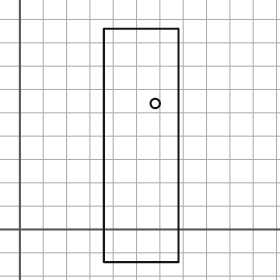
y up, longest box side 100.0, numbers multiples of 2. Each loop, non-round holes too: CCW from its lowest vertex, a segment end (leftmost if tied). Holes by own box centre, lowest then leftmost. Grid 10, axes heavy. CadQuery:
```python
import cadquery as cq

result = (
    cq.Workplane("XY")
    .moveTo(36.0, -14.0)
    .lineTo(68.0, -14.0)
    .lineTo(68.0, 86.0)
    .lineTo(36.0, 86.0)
    .close()
    .moveTo(58.0, 54.0)
    .circle(2.0)
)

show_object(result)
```